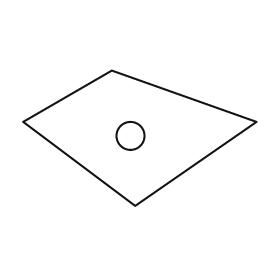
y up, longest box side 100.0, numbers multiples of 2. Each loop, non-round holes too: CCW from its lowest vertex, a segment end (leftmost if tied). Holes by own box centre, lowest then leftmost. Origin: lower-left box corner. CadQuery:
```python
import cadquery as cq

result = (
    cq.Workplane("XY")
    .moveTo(48.0, 0.0)
    .lineTo(100.0, 36.0)
    .lineTo(38.0, 58.0)
    .lineTo(0.0, 36.0)
    .close()
    .moveTo(46.0, 30.0)
    .circle(6.0)
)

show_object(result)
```